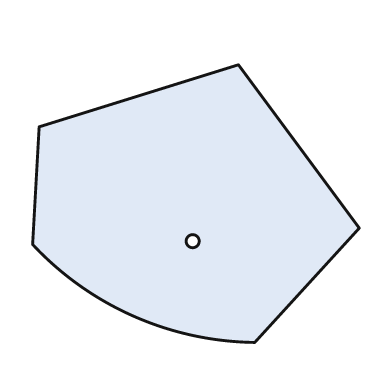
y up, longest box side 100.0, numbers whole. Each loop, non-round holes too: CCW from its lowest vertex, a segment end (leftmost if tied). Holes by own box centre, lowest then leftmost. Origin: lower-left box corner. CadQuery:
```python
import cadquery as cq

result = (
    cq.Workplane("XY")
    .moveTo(68.0, 0.0)
    .lineTo(100.0, 35.0)
    .lineTo(63.0, 85.0)
    .lineTo(2.0, 66.0)
    .lineTo(0.0, 30.0)
    .threePointArc((31.0, 8.0), (68.0, 0.0))
    .close()
    .moveTo(49.0, 31.0)
    .circle(2.0)
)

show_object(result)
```